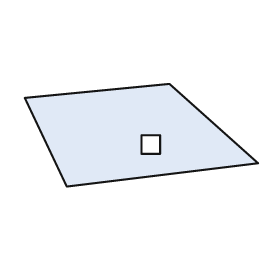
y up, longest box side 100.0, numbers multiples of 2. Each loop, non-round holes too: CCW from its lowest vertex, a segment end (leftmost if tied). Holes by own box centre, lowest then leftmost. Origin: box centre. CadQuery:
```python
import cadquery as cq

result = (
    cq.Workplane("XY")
    .moveTo(-32.0, -22.0)
    .lineTo(50.0, -12.0)
    .lineTo(12.0, 22.0)
    .lineTo(-50.0, 16.0)
    .close()
    .moveTo(0.0, -8.0)
    .lineTo(8.0, -8.0)
    .lineTo(8.0, 0.0)
    .lineTo(0.0, 0.0)
    .close()
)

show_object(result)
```